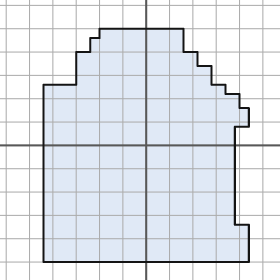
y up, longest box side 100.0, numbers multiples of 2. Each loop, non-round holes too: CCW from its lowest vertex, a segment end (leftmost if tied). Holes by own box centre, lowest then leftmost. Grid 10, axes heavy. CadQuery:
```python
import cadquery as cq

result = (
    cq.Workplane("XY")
    .moveTo(-44.0, -50.0)
    .lineTo(44.0, -50.0)
    .lineTo(44.0, -34.0)
    .lineTo(38.0, -34.0)
    .lineTo(38.0, 8.0)
    .lineTo(44.0, 8.0)
    .lineTo(44.0, 16.0)
    .lineTo(40.0, 16.0)
    .lineTo(40.0, 22.0)
    .lineTo(34.0, 22.0)
    .lineTo(34.0, 26.0)
    .lineTo(28.0, 26.0)
    .lineTo(28.0, 34.0)
    .lineTo(22.0, 34.0)
    .lineTo(22.0, 40.0)
    .lineTo(16.0, 40.0)
    .lineTo(16.0, 50.0)
    .lineTo(-20.0, 50.0)
    .lineTo(-20.0, 46.0)
    .lineTo(-24.0, 46.0)
    .lineTo(-24.0, 40.0)
    .lineTo(-30.0, 40.0)
    .lineTo(-30.0, 26.0)
    .lineTo(-44.0, 26.0)
    .close()
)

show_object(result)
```